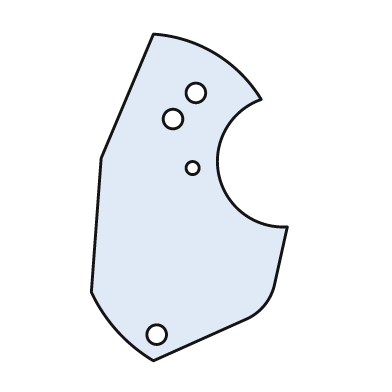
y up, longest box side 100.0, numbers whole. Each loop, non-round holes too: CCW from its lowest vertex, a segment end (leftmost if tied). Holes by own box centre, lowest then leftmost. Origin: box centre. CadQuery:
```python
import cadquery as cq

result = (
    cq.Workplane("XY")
    .moveTo(-11.0, -50.0)
    .lineTo(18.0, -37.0)
    .threePointArc((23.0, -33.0), (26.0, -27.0))
    .lineTo(30.0, -9.0)
    .threePointArc((9.0, 7.0), (22.0, 30.0))
    .threePointArc((8.0, 44.0), (-11.0, 50.0))
    .lineTo(-27.0, 12.0)
    .lineTo(-30.0, -29.0)
    .threePointArc((-22.0, -41.0), (-11.0, -50.0))
    .close()
    .moveTo(-10.0, -42.0)
    .circle(3.0)
    .moveTo(1.0, 9.0)
    .circle(2.0)
    .moveTo(-5.0, 24.0)
    .circle(3.0)
    .moveTo(2.0, 32.0)
    .circle(3.0)
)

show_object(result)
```